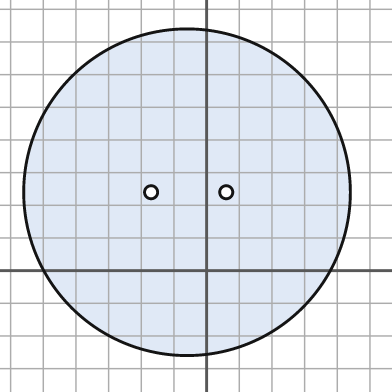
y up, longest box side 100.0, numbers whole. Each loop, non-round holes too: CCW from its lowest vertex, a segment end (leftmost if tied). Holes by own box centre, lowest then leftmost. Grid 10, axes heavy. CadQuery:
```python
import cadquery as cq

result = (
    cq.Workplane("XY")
    .moveTo(-6.0, 24.0)
    .circle(50.0)
    .moveTo(-17.0, 24.0)
    .circle(2.0)
    .moveTo(6.0, 24.0)
    .circle(2.0)
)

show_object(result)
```